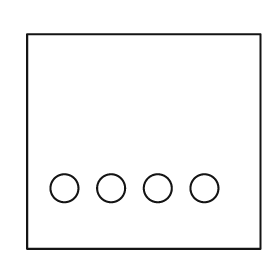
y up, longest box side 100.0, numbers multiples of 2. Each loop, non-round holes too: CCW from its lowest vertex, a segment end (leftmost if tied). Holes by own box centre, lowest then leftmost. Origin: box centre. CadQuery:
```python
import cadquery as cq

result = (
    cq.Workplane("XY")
    .moveTo(-50.0, -46.0)
    .lineTo(50.0, -46.0)
    .lineTo(50.0, 46.0)
    .lineTo(-50.0, 46.0)
    .close()
    .moveTo(-34.0, -20.0)
    .circle(6.0)
    .moveTo(-14.0, -20.0)
    .circle(6.0)
    .moveTo(6.0, -20.0)
    .circle(6.0)
    .moveTo(26.0, -20.0)
    .circle(6.0)
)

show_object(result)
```